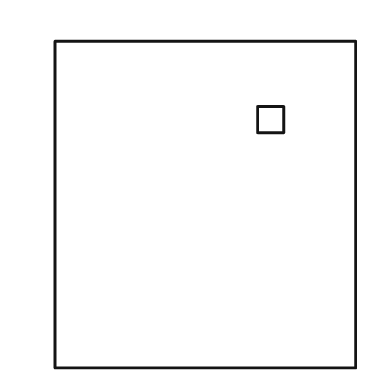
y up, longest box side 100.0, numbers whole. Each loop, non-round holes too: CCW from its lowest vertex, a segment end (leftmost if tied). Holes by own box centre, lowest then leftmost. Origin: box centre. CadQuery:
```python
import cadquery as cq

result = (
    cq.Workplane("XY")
    .moveTo(-46.0, -50.0)
    .lineTo(46.0, -50.0)
    .lineTo(46.0, 50.0)
    .lineTo(-46.0, 50.0)
    .close()
    .moveTo(16.0, 22.0)
    .lineTo(24.0, 22.0)
    .lineTo(24.0, 30.0)
    .lineTo(16.0, 30.0)
    .close()
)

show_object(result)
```